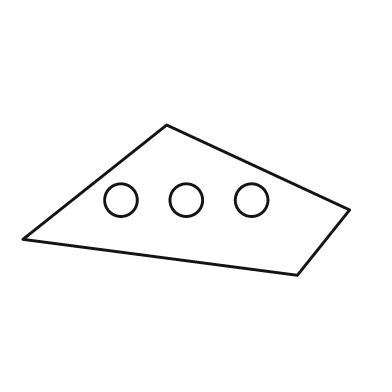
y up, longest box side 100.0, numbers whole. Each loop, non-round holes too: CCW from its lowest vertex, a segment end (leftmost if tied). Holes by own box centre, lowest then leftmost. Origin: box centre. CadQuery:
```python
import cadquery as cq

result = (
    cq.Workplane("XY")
    .moveTo(34.0, -23.0)
    .lineTo(50.0, -3.0)
    .lineTo(-6.0, 23.0)
    .lineTo(-50.0, -12.0)
    .close()
    .moveTo(-20.0, 0.0)
    .circle(5.0)
    .moveTo(0.0, 0.0)
    .circle(5.0)
    .moveTo(20.0, 0.0)
    .circle(5.0)
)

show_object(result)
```